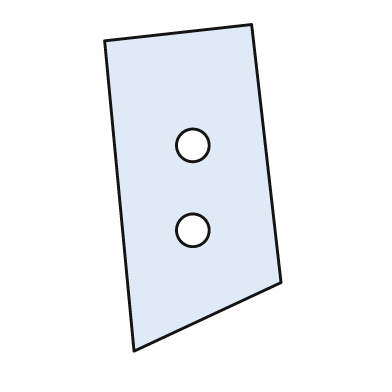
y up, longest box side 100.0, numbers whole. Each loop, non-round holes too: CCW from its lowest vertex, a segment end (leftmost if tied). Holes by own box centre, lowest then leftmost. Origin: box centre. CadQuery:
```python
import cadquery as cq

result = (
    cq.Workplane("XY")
    .moveTo(-18.0, -50.0)
    .lineTo(27.0, -29.0)
    .lineTo(18.0, 50.0)
    .lineTo(-27.0, 45.0)
    .close()
    .moveTo(0.0, -13.0)
    .circle(5.0)
    .moveTo(0.0, 13.0)
    .circle(5.0)
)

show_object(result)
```